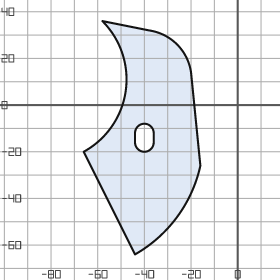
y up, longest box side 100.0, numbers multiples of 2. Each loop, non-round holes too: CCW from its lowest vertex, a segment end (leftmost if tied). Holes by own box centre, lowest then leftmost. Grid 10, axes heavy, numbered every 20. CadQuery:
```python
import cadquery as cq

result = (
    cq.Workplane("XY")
    .moveTo(-44.0, -64.0)
    .threePointArc((-26.0, -48.0), (-16.0, -26.0))
    .lineTo(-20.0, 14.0)
    .threePointArc((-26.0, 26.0), (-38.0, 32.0))
    .lineTo(-58.0, 36.0)
    .threePointArc((-48.0, 6.0), (-66.0, -20.0))
    .close()
    .moveTo(-44.0, -16.0)
    .threePointArc((-40.0, -20.0), (-36.0, -16.0))
    .lineTo(-36.0, -12.0)
    .threePointArc((-40.0, -8.0), (-44.0, -12.0))
    .close()
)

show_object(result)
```